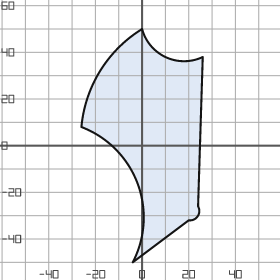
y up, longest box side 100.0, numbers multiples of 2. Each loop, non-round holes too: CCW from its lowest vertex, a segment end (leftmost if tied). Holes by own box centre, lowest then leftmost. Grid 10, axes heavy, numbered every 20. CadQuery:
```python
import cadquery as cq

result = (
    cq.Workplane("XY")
    .moveTo(-4.0, -50.0)
    .lineTo(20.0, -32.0)
    .threePointArc((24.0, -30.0), (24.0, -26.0))
    .lineTo(26.0, 38.0)
    .threePointArc((10.0, 38.0), (0.0, 50.0))
    .threePointArc((-18.0, 32.0), (-26.0, 8.0))
    .threePointArc((-2.0, -16.0), (-4.0, -50.0))
    .close()
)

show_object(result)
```